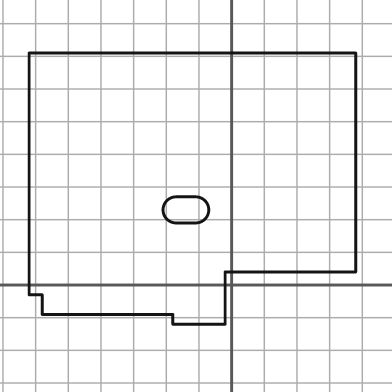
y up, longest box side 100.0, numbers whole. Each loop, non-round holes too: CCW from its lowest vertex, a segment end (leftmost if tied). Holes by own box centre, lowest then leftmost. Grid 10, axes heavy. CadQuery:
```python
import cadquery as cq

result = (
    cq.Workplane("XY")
    .moveTo(-18.0, -12.0)
    .lineTo(-2.0, -12.0)
    .lineTo(-2.0, 4.0)
    .lineTo(38.0, 4.0)
    .lineTo(38.0, 71.0)
    .lineTo(-62.0, 71.0)
    .lineTo(-62.0, -3.0)
    .lineTo(-58.0, -3.0)
    .lineTo(-58.0, -9.0)
    .lineTo(-18.0, -9.0)
    .close()
    .moveTo(-17.0, 19.0)
    .lineTo(-11.0, 19.0)
    .threePointArc((-7.0, 23.0), (-11.0, 27.0))
    .lineTo(-17.0, 27.0)
    .threePointArc((-21.0, 23.0), (-17.0, 19.0))
    .close()
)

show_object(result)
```